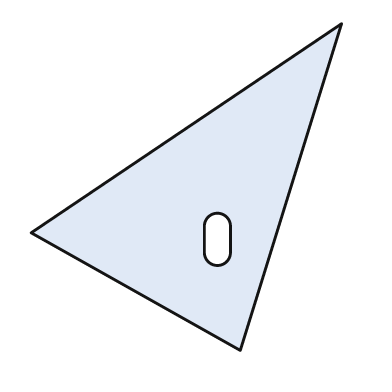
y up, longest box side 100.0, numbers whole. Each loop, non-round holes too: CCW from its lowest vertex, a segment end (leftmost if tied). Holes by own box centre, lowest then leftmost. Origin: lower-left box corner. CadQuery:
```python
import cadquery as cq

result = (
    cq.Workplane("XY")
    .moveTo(64.0, 0.0)
    .lineTo(95.0, 100.0)
    .lineTo(0.0, 36.0)
    .close()
    .moveTo(53.0, 30.0)
    .threePointArc((57.0, 26.0), (61.0, 30.0))
    .lineTo(61.0, 38.0)
    .threePointArc((57.0, 42.0), (53.0, 38.0))
    .close()
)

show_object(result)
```